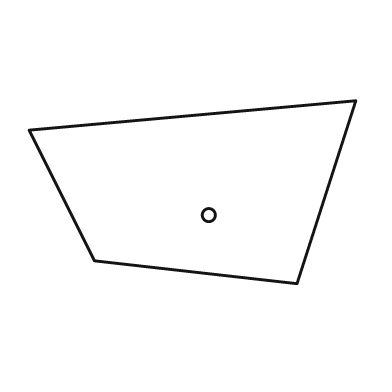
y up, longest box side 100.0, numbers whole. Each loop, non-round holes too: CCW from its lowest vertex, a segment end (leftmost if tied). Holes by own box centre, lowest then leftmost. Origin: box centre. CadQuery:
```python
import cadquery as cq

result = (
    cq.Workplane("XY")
    .moveTo(32.0, -28.0)
    .lineTo(50.0, 28.0)
    .lineTo(-50.0, 19.0)
    .lineTo(-30.0, -21.0)
    .close()
    .moveTo(5.0, -7.0)
    .circle(2.0)
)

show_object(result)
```